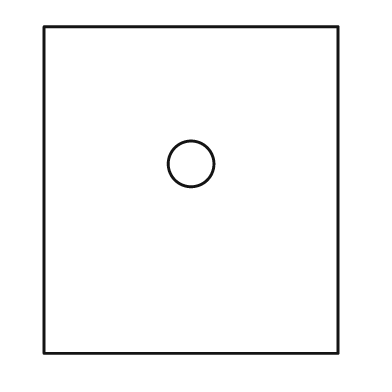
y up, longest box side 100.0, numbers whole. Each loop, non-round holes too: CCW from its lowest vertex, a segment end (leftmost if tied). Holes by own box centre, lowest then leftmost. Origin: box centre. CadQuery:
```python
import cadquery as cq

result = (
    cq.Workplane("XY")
    .moveTo(-45.0, -50.0)
    .lineTo(45.0, -50.0)
    .lineTo(45.0, 50.0)
    .lineTo(-45.0, 50.0)
    .close()
    .moveTo(0.0, 8.0)
    .circle(7.0)
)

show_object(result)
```